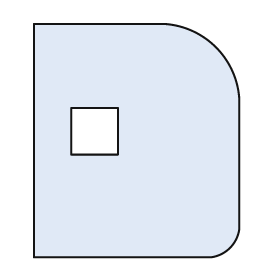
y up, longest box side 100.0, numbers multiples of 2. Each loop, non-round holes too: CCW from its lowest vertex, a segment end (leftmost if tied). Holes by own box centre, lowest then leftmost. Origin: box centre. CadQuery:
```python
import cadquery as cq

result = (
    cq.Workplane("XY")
    .moveTo(-44.0, -50.0)
    .lineTo(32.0, -50.0)
    .threePointArc((40.0, -46.0), (44.0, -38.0))
    .lineTo(44.0, 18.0)
    .threePointArc((34.0, 40.0), (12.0, 50.0))
    .lineTo(-44.0, 50.0)
    .close()
    .moveTo(-28.0, -6.0)
    .lineTo(-8.0, -6.0)
    .lineTo(-8.0, 14.0)
    .lineTo(-28.0, 14.0)
    .close()
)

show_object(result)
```